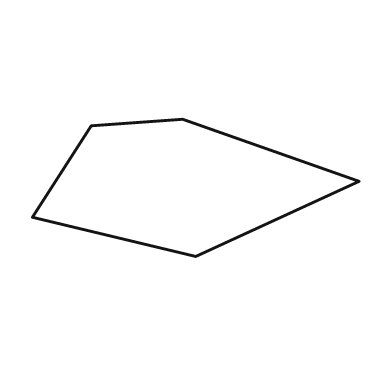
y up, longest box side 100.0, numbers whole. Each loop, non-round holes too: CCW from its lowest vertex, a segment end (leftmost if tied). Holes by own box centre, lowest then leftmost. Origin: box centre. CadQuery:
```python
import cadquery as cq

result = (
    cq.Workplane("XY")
    .moveTo(0.0, -21.0)
    .lineTo(50.0, 2.0)
    .lineTo(-4.0, 21.0)
    .lineTo(-32.0, 19.0)
    .lineTo(-50.0, -9.0)
    .close()
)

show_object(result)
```